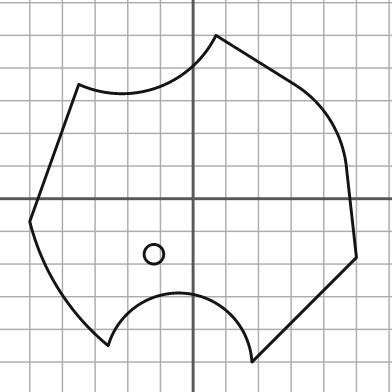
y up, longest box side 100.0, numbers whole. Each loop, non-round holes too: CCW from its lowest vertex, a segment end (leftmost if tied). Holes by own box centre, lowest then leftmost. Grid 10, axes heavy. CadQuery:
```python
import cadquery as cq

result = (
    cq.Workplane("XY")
    .moveTo(18.0, -50.0)
    .lineTo(50.0, -18.0)
    .lineTo(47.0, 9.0)
    .threePointArc((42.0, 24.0), (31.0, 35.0))
    .lineTo(7.0, 50.0)
    .threePointArc((-11.0, 34.0), (-35.0, 35.0))
    .lineTo(-50.0, -7.0)
    .threePointArc((-41.0, -28.0), (-26.0, -45.0))
    .threePointArc((-2.0, -29.0), (18.0, -50.0))
    .close()
    .moveTo(-12.0, -17.0)
    .circle(3.0)
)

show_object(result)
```